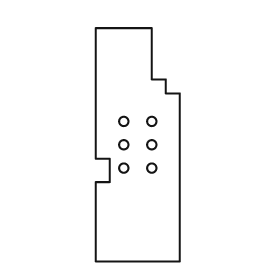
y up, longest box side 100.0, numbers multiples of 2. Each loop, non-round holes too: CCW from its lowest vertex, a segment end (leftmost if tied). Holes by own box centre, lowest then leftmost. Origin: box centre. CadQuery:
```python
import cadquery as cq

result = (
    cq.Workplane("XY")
    .moveTo(-18.0, -50.0)
    .lineTo(18.0, -50.0)
    .lineTo(18.0, 22.0)
    .lineTo(12.0, 22.0)
    .lineTo(12.0, 28.0)
    .lineTo(6.0, 28.0)
    .lineTo(6.0, 50.0)
    .lineTo(-18.0, 50.0)
    .lineTo(-18.0, -6.0)
    .lineTo(-12.0, -6.0)
    .lineTo(-12.0, -16.0)
    .lineTo(-18.0, -16.0)
    .close()
    .moveTo(-6.0, -10.0)
    .circle(2.0)
    .moveTo(6.0, -10.0)
    .circle(2.0)
    .moveTo(-6.0, 0.0)
    .circle(2.0)
    .moveTo(6.0, 0.0)
    .circle(2.0)
    .moveTo(-6.0, 10.0)
    .circle(2.0)
    .moveTo(6.0, 10.0)
    .circle(2.0)
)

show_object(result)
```